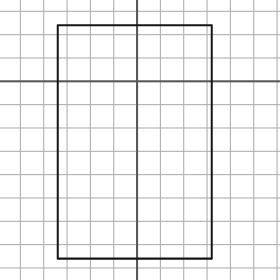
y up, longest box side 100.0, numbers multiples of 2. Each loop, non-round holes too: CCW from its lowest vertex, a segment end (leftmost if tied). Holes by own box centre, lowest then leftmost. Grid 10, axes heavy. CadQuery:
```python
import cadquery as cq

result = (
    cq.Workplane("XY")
    .moveTo(-34.0, -76.0)
    .lineTo(32.0, -76.0)
    .lineTo(32.0, 24.0)
    .lineTo(-34.0, 24.0)
    .close()
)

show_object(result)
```